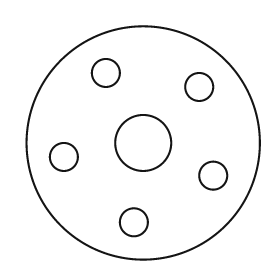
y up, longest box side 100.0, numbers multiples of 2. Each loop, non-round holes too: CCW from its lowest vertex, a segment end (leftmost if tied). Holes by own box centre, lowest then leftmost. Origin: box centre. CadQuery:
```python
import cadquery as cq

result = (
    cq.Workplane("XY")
    .moveTo(0.0, 0.0)
    .circle(50.0)
    .moveTo(-4.0, -34.0)
    .circle(6.0)
    .moveTo(30.0, -14.0)
    .circle(6.0)
    .moveTo(-34.0, -6.0)
    .circle(6.0)
    .moveTo(0.0, 0.0)
    .circle(12.0)
    .moveTo(24.0, 24.0)
    .circle(6.0)
    .moveTo(-16.0, 30.0)
    .circle(6.0)
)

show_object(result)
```